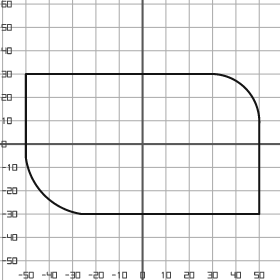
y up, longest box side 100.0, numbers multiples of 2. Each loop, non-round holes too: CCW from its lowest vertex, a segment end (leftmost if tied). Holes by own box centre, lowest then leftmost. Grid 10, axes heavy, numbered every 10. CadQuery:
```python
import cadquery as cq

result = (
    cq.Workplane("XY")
    .moveTo(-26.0, -30.0)
    .lineTo(50.0, -30.0)
    .lineTo(50.0, 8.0)
    .threePointArc((44.0, 24.0), (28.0, 30.0))
    .lineTo(-50.0, 30.0)
    .lineTo(-50.0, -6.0)
    .threePointArc((-42.0, -22.0), (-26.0, -30.0))
    .close()
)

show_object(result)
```